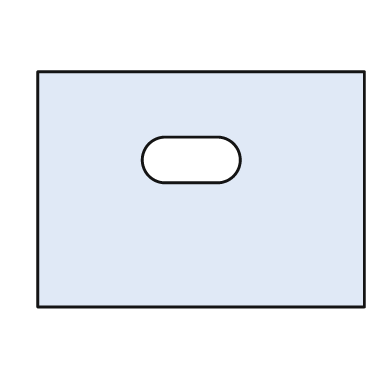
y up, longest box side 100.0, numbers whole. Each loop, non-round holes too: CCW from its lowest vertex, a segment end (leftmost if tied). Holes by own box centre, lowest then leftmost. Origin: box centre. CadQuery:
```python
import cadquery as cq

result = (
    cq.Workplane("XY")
    .moveTo(-50.0, -36.0)
    .lineTo(50.0, -36.0)
    .lineTo(50.0, 36.0)
    .lineTo(-50.0, 36.0)
    .close()
    .moveTo(-11.0, 2.0)
    .lineTo(5.0, 2.0)
    .threePointArc((12.0, 9.0), (5.0, 16.0))
    .lineTo(-11.0, 16.0)
    .threePointArc((-18.0, 9.0), (-11.0, 2.0))
    .close()
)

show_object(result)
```